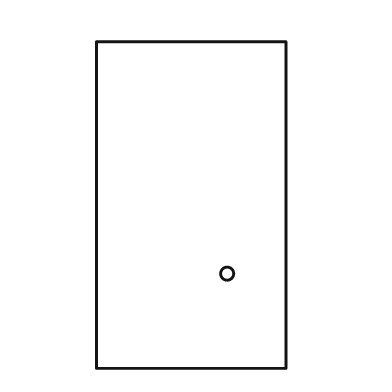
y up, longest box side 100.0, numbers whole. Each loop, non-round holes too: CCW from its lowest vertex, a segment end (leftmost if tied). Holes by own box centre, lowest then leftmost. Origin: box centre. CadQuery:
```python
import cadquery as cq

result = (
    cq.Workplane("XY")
    .moveTo(-29.0, -50.0)
    .lineTo(29.0, -50.0)
    .lineTo(29.0, 50.0)
    .lineTo(-29.0, 50.0)
    .close()
    .moveTo(11.0, -21.0)
    .circle(2.0)
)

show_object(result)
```